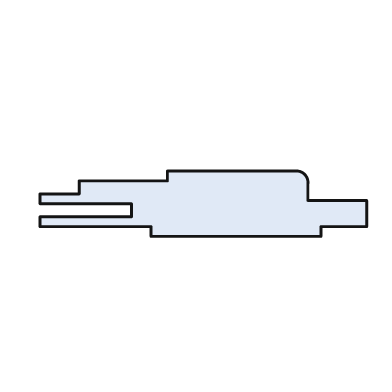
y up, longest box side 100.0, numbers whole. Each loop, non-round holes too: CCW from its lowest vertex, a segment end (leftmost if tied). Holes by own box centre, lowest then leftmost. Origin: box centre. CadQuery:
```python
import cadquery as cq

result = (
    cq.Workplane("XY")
    .moveTo(-16.0, -10.0)
    .lineTo(36.0, -10.0)
    .lineTo(36.0, -7.0)
    .lineTo(50.0, -7.0)
    .lineTo(50.0, 1.0)
    .lineTo(32.0, 1.0)
    .lineTo(32.0, 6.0)
    .threePointArc((31.0, 9.0), (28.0, 10.0))
    .lineTo(-11.0, 10.0)
    .lineTo(-11.0, 7.0)
    .lineTo(-38.0, 7.0)
    .lineTo(-38.0, 3.0)
    .lineTo(-50.0, 3.0)
    .lineTo(-50.0, 0.0)
    .lineTo(-22.0, 0.0)
    .lineTo(-22.0, -4.0)
    .lineTo(-50.0, -4.0)
    .lineTo(-50.0, -7.0)
    .lineTo(-16.0, -7.0)
    .close()
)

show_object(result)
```